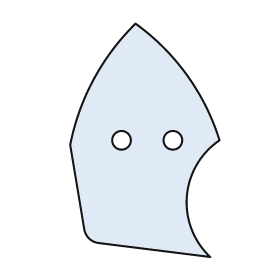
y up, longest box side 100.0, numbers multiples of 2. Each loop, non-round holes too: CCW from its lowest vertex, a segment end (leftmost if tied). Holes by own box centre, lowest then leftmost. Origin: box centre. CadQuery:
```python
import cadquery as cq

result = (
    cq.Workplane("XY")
    .moveTo(28.0, -50.0)
    .threePointArc((18.0, -24.0), (32.0, 0.0))
    .threePointArc((18.0, 28.0), (-4.0, 50.0))
    .threePointArc((-22.0, 26.0), (-32.0, -2.0))
    .lineTo(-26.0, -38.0)
    .threePointArc((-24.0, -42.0), (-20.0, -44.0))
    .close()
    .moveTo(-10.0, 0.0)
    .circle(4.0)
    .moveTo(12.0, 0.0)
    .circle(4.0)
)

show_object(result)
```